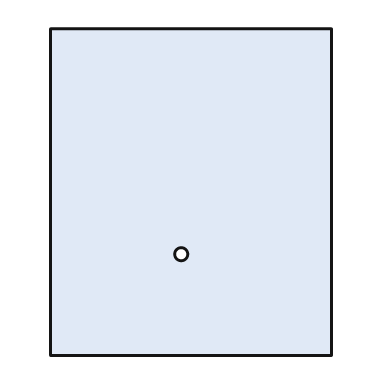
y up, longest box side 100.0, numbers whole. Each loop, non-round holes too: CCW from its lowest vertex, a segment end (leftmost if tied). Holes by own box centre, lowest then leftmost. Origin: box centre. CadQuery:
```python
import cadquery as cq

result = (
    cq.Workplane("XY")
    .moveTo(-43.0, -50.0)
    .lineTo(43.0, -50.0)
    .lineTo(43.0, 50.0)
    .lineTo(-43.0, 50.0)
    .close()
    .moveTo(-3.0, -19.0)
    .circle(2.0)
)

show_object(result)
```